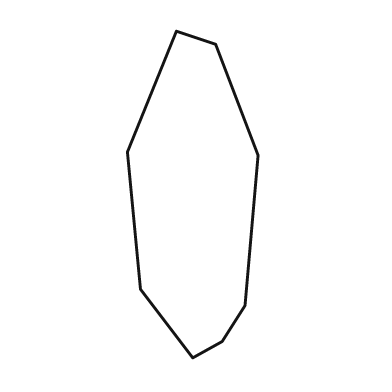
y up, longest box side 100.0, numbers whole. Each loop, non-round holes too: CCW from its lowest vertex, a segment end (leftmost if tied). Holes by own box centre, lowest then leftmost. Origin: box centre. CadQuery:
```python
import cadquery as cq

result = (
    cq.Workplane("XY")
    .moveTo(0.0, -50.0)
    .lineTo(9.0, -45.0)
    .lineTo(16.0, -34.0)
    .lineTo(20.0, 12.0)
    .lineTo(7.0, 46.0)
    .lineTo(-5.0, 50.0)
    .lineTo(-20.0, 13.0)
    .lineTo(-16.0, -29.0)
    .close()
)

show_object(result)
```